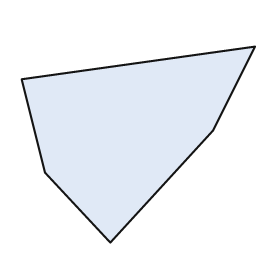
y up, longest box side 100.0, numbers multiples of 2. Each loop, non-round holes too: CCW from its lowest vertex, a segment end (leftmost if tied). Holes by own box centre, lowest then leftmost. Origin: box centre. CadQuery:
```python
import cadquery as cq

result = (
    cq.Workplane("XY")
    .moveTo(-12.0, -42.0)
    .lineTo(32.0, 6.0)
    .lineTo(50.0, 42.0)
    .lineTo(-50.0, 28.0)
    .lineTo(-40.0, -12.0)
    .close()
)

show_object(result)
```